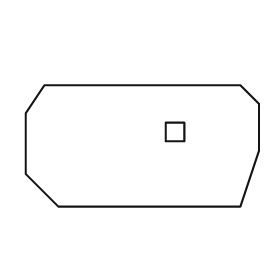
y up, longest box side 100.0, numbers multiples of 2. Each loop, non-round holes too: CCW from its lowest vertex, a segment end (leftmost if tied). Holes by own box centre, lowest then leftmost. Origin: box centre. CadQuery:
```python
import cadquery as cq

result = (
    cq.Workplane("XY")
    .moveTo(-36.0, -26.0)
    .lineTo(42.0, -26.0)
    .lineTo(50.0, -2.0)
    .lineTo(50.0, 18.0)
    .lineTo(42.0, 26.0)
    .lineTo(-42.0, 26.0)
    .lineTo(-50.0, 14.0)
    .lineTo(-50.0, -12.0)
    .close()
    .moveTo(10.0, 2.0)
    .lineTo(18.0, 2.0)
    .lineTo(18.0, 10.0)
    .lineTo(10.0, 10.0)
    .close()
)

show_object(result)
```